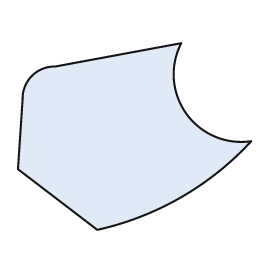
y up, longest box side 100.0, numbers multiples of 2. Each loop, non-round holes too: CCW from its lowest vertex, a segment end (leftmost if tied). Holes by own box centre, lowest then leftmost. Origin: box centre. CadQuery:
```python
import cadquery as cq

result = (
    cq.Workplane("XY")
    .moveTo(-16.0, -40.0)
    .threePointArc((20.0, -26.0), (50.0, -2.0))
    .threePointArc((22.0, 10.0), (20.0, 40.0))
    .lineTo(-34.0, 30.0)
    .threePointArc((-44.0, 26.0), (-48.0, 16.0))
    .lineTo(-50.0, -14.0)
    .close()
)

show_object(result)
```